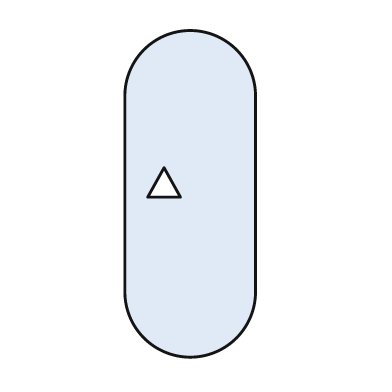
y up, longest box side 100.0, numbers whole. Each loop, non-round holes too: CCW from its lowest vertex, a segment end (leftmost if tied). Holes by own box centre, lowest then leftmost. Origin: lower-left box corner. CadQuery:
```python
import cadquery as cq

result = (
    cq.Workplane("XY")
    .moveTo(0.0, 20.0)
    .threePointArc((20.0, 0.0), (40.0, 20.0))
    .lineTo(40.0, 80.0)
    .threePointArc((20.0, 100.0), (0.0, 80.0))
    .close()
    .moveTo(7.0, 49.0)
    .lineTo(17.0, 49.0)
    .lineTo(12.0, 58.0)
    .close()
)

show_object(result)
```